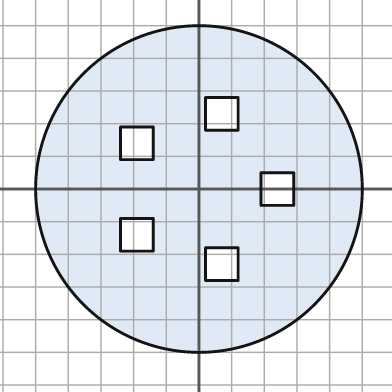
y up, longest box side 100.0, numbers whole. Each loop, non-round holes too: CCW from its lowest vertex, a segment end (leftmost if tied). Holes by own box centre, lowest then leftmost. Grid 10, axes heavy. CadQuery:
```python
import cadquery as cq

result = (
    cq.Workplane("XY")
    .moveTo(0.0, 0.0)
    .circle(50.0)
    .moveTo(2.0, -28.0)
    .lineTo(12.0, -28.0)
    .lineTo(12.0, -18.0)
    .lineTo(2.0, -18.0)
    .close()
    .moveTo(-24.0, -19.0)
    .lineTo(-14.0, -19.0)
    .lineTo(-14.0, -9.0)
    .lineTo(-24.0, -9.0)
    .close()
    .moveTo(19.0, -5.0)
    .lineTo(29.0, -5.0)
    .lineTo(29.0, 5.0)
    .lineTo(19.0, 5.0)
    .close()
    .moveTo(-24.0, 9.0)
    .lineTo(-14.0, 9.0)
    .lineTo(-14.0, 19.0)
    .lineTo(-24.0, 19.0)
    .close()
    .moveTo(2.0, 18.0)
    .lineTo(12.0, 18.0)
    .lineTo(12.0, 28.0)
    .lineTo(2.0, 28.0)
    .close()
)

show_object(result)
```